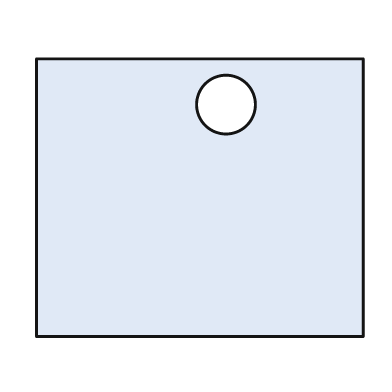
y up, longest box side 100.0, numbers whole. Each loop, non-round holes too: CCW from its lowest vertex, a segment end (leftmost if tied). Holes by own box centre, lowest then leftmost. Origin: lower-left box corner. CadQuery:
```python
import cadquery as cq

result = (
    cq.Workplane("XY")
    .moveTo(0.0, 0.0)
    .lineTo(100.0, 0.0)
    .lineTo(100.0, 85.0)
    .lineTo(0.0, 85.0)
    .close()
    .moveTo(58.0, 71.0)
    .circle(9.0)
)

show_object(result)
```